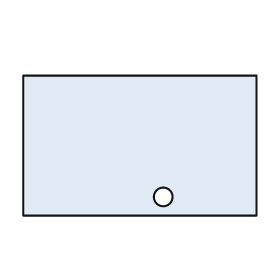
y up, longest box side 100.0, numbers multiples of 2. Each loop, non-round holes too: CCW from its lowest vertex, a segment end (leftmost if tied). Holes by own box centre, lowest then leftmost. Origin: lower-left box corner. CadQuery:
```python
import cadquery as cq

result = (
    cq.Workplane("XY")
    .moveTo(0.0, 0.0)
    .lineTo(100.0, 0.0)
    .lineTo(100.0, 60.0)
    .lineTo(0.0, 60.0)
    .close()
    .moveTo(60.0, 8.0)
    .circle(4.0)
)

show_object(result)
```